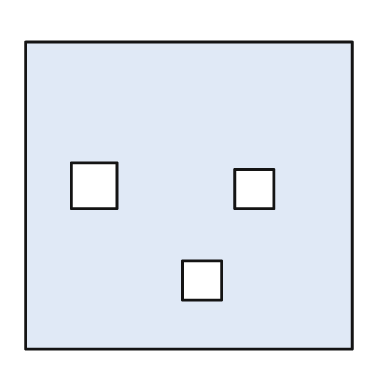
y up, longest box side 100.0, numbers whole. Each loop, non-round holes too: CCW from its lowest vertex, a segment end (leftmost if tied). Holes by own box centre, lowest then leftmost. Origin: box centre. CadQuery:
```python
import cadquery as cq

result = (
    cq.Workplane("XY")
    .moveTo(-50.0, -47.0)
    .lineTo(50.0, -47.0)
    .lineTo(50.0, 47.0)
    .lineTo(-50.0, 47.0)
    .close()
    .moveTo(-2.0, -32.0)
    .lineTo(10.0, -32.0)
    .lineTo(10.0, -20.0)
    .lineTo(-2.0, -20.0)
    .close()
    .moveTo(14.0, -4.0)
    .lineTo(26.0, -4.0)
    .lineTo(26.0, 8.0)
    .lineTo(14.0, 8.0)
    .close()
    .moveTo(-36.0, -4.0)
    .lineTo(-22.0, -4.0)
    .lineTo(-22.0, 10.0)
    .lineTo(-36.0, 10.0)
    .close()
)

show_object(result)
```